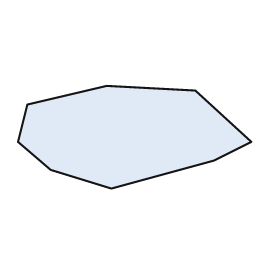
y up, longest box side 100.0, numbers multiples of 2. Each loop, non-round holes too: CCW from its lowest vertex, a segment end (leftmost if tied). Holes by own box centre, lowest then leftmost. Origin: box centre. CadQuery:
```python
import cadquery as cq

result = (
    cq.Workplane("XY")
    .moveTo(-10.0, -22.0)
    .lineTo(34.0, -10.0)
    .lineTo(50.0, -2.0)
    .lineTo(26.0, 20.0)
    .lineTo(-12.0, 22.0)
    .lineTo(-46.0, 14.0)
    .lineTo(-50.0, -2.0)
    .lineTo(-36.0, -14.0)
    .close()
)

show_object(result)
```